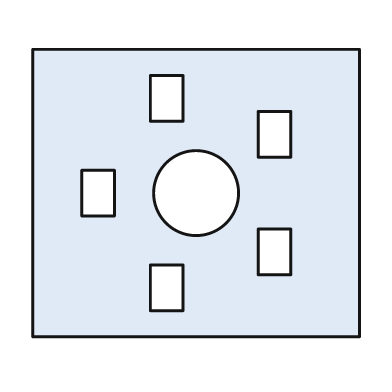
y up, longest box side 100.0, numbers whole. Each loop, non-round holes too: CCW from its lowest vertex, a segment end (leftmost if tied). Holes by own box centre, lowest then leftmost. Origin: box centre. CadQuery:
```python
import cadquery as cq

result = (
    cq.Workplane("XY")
    .moveTo(-50.0, -44.0)
    .lineTo(50.0, -44.0)
    .lineTo(50.0, 44.0)
    .lineTo(-50.0, 44.0)
    .close()
    .moveTo(-14.0, -36.0)
    .lineTo(-4.0, -36.0)
    .lineTo(-4.0, -22.0)
    .lineTo(-14.0, -22.0)
    .close()
    .moveTo(19.0, -25.0)
    .lineTo(29.0, -25.0)
    .lineTo(29.0, -11.0)
    .lineTo(19.0, -11.0)
    .close()
    .moveTo(-35.0, -7.0)
    .lineTo(-25.0, -7.0)
    .lineTo(-25.0, 7.0)
    .lineTo(-35.0, 7.0)
    .close()
    .moveTo(0.0, 0.0)
    .circle(13.0)
    .moveTo(19.0, 11.0)
    .lineTo(29.0, 11.0)
    .lineTo(29.0, 25.0)
    .lineTo(19.0, 25.0)
    .close()
    .moveTo(-14.0, 22.0)
    .lineTo(-4.0, 22.0)
    .lineTo(-4.0, 36.0)
    .lineTo(-14.0, 36.0)
    .close()
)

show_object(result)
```